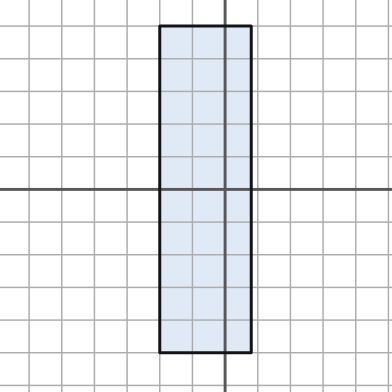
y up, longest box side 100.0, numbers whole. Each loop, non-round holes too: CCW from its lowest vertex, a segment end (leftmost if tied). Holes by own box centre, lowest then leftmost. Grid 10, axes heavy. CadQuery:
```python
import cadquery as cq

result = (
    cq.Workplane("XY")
    .moveTo(-20.0, -50.0)
    .lineTo(8.0, -50.0)
    .lineTo(8.0, 50.0)
    .lineTo(-20.0, 50.0)
    .close()
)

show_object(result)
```